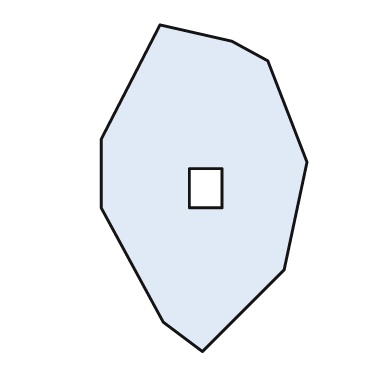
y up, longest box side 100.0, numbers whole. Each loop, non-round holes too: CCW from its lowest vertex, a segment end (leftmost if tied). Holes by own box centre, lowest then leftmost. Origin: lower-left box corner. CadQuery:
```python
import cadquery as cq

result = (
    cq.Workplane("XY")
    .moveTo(31.0, 0.0)
    .lineTo(56.0, 25.0)
    .lineTo(63.0, 58.0)
    .lineTo(51.0, 89.0)
    .lineTo(40.0, 95.0)
    .lineTo(18.0, 100.0)
    .lineTo(0.0, 65.0)
    .lineTo(0.0, 44.0)
    .lineTo(19.0, 9.0)
    .close()
    .moveTo(27.0, 44.0)
    .lineTo(37.0, 44.0)
    .lineTo(37.0, 56.0)
    .lineTo(27.0, 56.0)
    .close()
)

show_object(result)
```